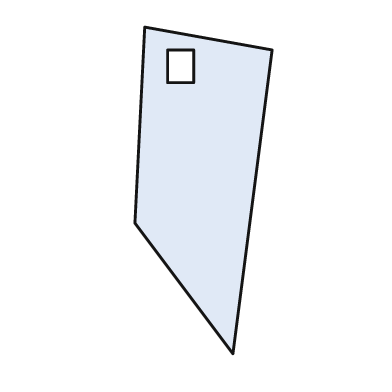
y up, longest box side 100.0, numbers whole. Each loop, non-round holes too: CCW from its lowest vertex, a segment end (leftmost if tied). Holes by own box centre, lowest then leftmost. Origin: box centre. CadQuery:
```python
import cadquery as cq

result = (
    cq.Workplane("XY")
    .moveTo(9.0, -50.0)
    .lineTo(21.0, 43.0)
    .lineTo(-18.0, 50.0)
    .lineTo(-21.0, -10.0)
    .close()
    .moveTo(-11.0, 33.0)
    .lineTo(-3.0, 33.0)
    .lineTo(-3.0, 43.0)
    .lineTo(-11.0, 43.0)
    .close()
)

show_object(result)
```